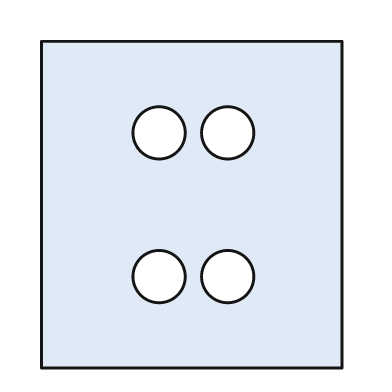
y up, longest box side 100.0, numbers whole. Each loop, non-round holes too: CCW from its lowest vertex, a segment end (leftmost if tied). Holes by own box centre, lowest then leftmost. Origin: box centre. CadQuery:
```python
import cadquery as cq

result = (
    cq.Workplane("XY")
    .moveTo(-46.0, -50.0)
    .lineTo(46.0, -50.0)
    .lineTo(46.0, 50.0)
    .lineTo(-46.0, 50.0)
    .close()
    .moveTo(-10.0, -22.0)
    .circle(8.0)
    .moveTo(11.0, -22.0)
    .circle(8.0)
    .moveTo(-10.0, 22.0)
    .circle(8.0)
    .moveTo(11.0, 22.0)
    .circle(8.0)
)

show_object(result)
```